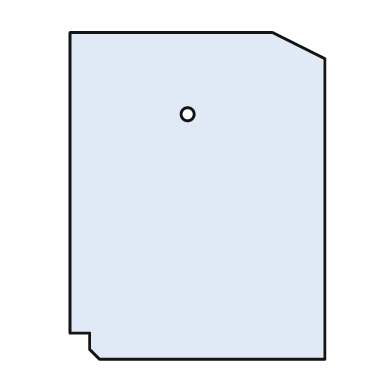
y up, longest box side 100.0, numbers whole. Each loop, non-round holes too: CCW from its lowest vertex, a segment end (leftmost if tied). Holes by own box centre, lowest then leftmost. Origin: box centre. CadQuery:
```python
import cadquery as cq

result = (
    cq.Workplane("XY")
    .moveTo(-30.0, -50.0)
    .lineTo(39.0, -50.0)
    .lineTo(39.0, 42.0)
    .lineTo(23.0, 50.0)
    .lineTo(-39.0, 50.0)
    .lineTo(-39.0, -42.0)
    .lineTo(-33.0, -42.0)
    .lineTo(-33.0, -47.0)
    .close()
    .moveTo(-3.0, 25.0)
    .circle(2.0)
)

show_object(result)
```